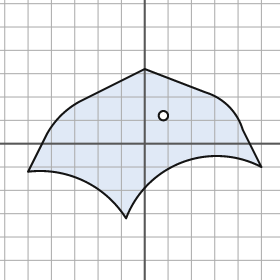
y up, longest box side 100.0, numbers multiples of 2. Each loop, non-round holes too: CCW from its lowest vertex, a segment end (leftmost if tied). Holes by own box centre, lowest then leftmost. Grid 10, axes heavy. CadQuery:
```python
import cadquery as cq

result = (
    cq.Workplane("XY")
    .moveTo(-8.0, -32.0)
    .threePointArc((16.0, -8.0), (50.0, -10.0))
    .lineTo(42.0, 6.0)
    .threePointArc((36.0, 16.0), (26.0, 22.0))
    .lineTo(0.0, 32.0)
    .lineTo(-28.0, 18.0)
    .threePointArc((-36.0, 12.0), (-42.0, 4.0))
    .lineTo(-50.0, -12.0)
    .threePointArc((-26.0, -16.0), (-8.0, -32.0))
    .close()
    .moveTo(8.0, 12.0)
    .circle(2.0)
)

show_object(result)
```